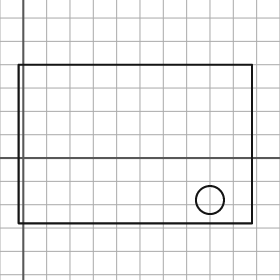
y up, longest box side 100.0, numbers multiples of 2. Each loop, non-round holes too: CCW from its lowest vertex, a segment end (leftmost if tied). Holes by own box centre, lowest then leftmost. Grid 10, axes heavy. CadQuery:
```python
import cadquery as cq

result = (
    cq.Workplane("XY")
    .moveTo(-2.0, -28.0)
    .lineTo(98.0, -28.0)
    .lineTo(98.0, 40.0)
    .lineTo(-2.0, 40.0)
    .close()
    .moveTo(80.0, -18.0)
    .circle(6.0)
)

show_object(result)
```